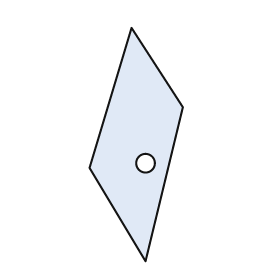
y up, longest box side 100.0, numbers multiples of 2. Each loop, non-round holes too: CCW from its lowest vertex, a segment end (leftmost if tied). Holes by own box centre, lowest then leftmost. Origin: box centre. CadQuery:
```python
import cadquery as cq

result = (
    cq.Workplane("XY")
    .moveTo(4.0, -50.0)
    .lineTo(20.0, 16.0)
    .lineTo(-2.0, 50.0)
    .lineTo(-20.0, -10.0)
    .close()
    .moveTo(4.0, -8.0)
    .circle(4.0)
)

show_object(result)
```